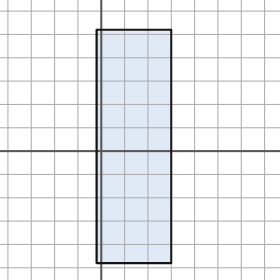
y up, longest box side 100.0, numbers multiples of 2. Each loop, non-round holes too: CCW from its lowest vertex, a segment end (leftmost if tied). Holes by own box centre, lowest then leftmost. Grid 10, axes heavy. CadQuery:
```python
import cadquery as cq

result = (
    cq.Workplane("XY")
    .moveTo(-2.0, -48.0)
    .lineTo(30.0, -48.0)
    .lineTo(30.0, 52.0)
    .lineTo(-2.0, 52.0)
    .close()
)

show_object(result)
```